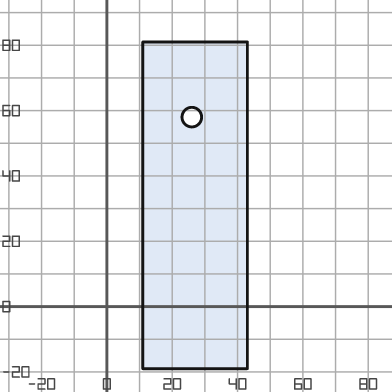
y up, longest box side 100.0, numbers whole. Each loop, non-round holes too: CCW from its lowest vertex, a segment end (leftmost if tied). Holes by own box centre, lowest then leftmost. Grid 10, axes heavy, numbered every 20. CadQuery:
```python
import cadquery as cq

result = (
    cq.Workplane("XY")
    .moveTo(11.0, -19.0)
    .lineTo(43.0, -19.0)
    .lineTo(43.0, 81.0)
    .lineTo(11.0, 81.0)
    .close()
    .moveTo(26.0, 58.0)
    .circle(3.0)
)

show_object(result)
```